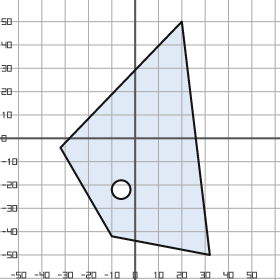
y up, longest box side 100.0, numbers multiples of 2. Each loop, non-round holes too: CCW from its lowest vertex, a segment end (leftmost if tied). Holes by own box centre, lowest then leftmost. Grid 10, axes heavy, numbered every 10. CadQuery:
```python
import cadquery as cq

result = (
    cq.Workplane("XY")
    .moveTo(32.0, -50.0)
    .lineTo(20.0, 50.0)
    .lineTo(-32.0, -4.0)
    .lineTo(-10.0, -42.0)
    .close()
    .moveTo(-6.0, -22.0)
    .circle(4.0)
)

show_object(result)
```